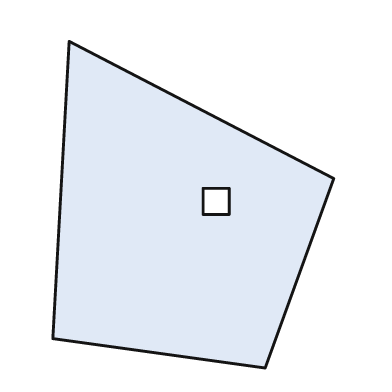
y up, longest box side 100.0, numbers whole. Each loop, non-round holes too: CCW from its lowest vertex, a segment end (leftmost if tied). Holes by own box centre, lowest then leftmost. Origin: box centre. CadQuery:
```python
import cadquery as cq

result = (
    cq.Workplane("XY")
    .moveTo(22.0, -50.0)
    .lineTo(43.0, 8.0)
    .lineTo(-38.0, 50.0)
    .lineTo(-43.0, -41.0)
    .close()
    .moveTo(3.0, -3.0)
    .lineTo(11.0, -3.0)
    .lineTo(11.0, 5.0)
    .lineTo(3.0, 5.0)
    .close()
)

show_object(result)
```